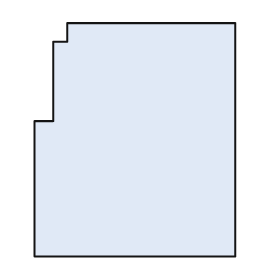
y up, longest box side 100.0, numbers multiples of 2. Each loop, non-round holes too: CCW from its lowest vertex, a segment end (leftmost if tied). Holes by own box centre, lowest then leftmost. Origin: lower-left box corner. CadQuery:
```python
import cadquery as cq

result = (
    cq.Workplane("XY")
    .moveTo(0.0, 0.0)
    .lineTo(86.0, 0.0)
    .lineTo(86.0, 100.0)
    .lineTo(14.0, 100.0)
    .lineTo(14.0, 92.0)
    .lineTo(8.0, 92.0)
    .lineTo(8.0, 58.0)
    .lineTo(0.0, 58.0)
    .close()
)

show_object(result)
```